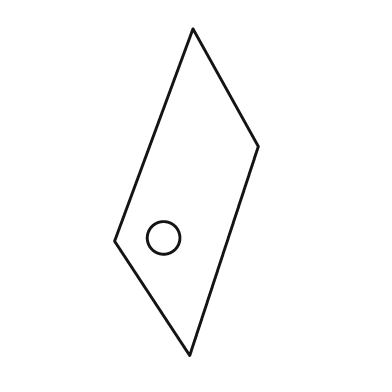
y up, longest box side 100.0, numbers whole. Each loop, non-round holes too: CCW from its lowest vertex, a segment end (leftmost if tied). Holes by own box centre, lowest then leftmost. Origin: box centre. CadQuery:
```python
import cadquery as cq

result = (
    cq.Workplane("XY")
    .moveTo(1.0, -50.0)
    .lineTo(22.0, 14.0)
    .lineTo(2.0, 50.0)
    .lineTo(-22.0, -15.0)
    .close()
    .moveTo(-7.0, -14.0)
    .circle(5.0)
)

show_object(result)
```